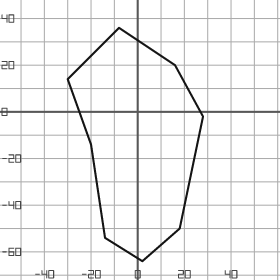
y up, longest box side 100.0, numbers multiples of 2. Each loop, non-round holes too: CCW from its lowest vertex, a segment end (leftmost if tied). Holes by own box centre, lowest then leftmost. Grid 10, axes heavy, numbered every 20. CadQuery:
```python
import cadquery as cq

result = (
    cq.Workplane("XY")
    .moveTo(2.0, -64.0)
    .lineTo(18.0, -50.0)
    .lineTo(28.0, -2.0)
    .lineTo(16.0, 20.0)
    .lineTo(-8.0, 36.0)
    .lineTo(-30.0, 14.0)
    .lineTo(-20.0, -14.0)
    .lineTo(-14.0, -54.0)
    .close()
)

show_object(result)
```